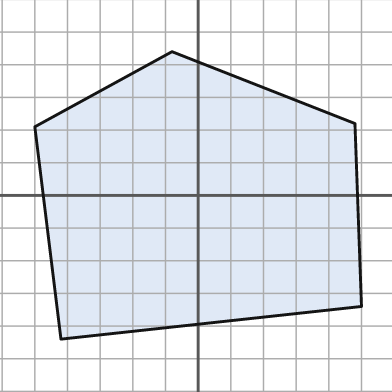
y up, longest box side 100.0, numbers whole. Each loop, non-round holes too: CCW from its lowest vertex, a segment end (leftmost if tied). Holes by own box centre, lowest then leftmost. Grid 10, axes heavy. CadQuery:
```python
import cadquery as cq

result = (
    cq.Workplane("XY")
    .moveTo(-42.0, -44.0)
    .lineTo(50.0, -34.0)
    .lineTo(48.0, 22.0)
    .lineTo(-8.0, 44.0)
    .lineTo(-50.0, 21.0)
    .close()
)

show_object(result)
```